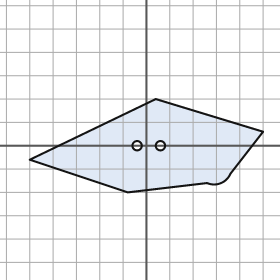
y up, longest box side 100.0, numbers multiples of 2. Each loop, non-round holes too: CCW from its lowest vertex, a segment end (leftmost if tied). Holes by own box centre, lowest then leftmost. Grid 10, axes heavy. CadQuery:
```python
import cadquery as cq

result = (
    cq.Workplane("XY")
    .moveTo(-8.0, -20.0)
    .lineTo(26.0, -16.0)
    .threePointArc((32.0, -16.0), (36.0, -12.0))
    .lineTo(50.0, 6.0)
    .lineTo(4.0, 20.0)
    .lineTo(-50.0, -6.0)
    .close()
    .moveTo(-4.0, 0.0)
    .circle(2.0)
    .moveTo(6.0, 0.0)
    .circle(2.0)
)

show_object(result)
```